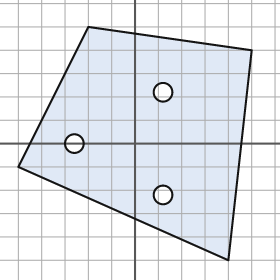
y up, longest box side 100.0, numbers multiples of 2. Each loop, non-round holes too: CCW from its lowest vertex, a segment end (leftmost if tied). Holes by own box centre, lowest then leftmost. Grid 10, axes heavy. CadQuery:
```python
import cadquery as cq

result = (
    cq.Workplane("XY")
    .moveTo(40.0, -50.0)
    .lineTo(50.0, 40.0)
    .lineTo(-20.0, 50.0)
    .lineTo(-50.0, -10.0)
    .close()
    .moveTo(12.0, -22.0)
    .circle(4.0)
    .moveTo(-26.0, 0.0)
    .circle(4.0)
    .moveTo(12.0, 22.0)
    .circle(4.0)
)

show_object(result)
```